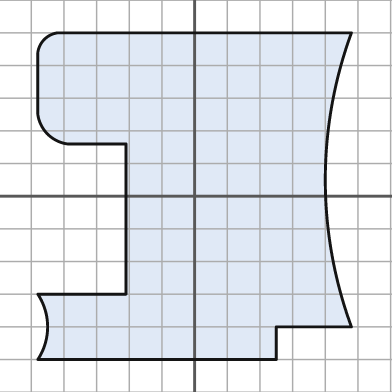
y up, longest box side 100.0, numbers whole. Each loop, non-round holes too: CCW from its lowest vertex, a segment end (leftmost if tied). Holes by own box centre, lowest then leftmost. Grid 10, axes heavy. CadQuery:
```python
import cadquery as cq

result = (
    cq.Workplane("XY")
    .moveTo(-48.0, -50.0)
    .lineTo(25.0, -50.0)
    .lineTo(25.0, -40.0)
    .lineTo(48.0, -40.0)
    .threePointArc((40.0, 5.0), (48.0, 50.0))
    .lineTo(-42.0, 50.0)
    .threePointArc((-46.0, 48.0), (-48.0, 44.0))
    .lineTo(-48.0, 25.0)
    .threePointArc((-45.0, 19.0), (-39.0, 16.0))
    .lineTo(-21.0, 16.0)
    .lineTo(-21.0, -30.0)
    .lineTo(-48.0, -30.0)
    .threePointArc((-45.0, -40.0), (-48.0, -50.0))
    .close()
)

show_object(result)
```